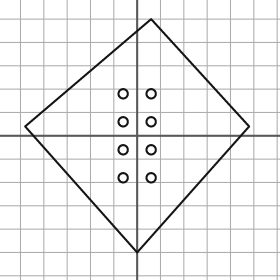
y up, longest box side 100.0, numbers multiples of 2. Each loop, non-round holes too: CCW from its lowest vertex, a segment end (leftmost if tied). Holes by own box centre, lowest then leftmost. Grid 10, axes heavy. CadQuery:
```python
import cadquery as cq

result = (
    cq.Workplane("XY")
    .moveTo(0.0, -50.0)
    .lineTo(48.0, 4.0)
    .lineTo(6.0, 50.0)
    .lineTo(-48.0, 4.0)
    .close()
    .moveTo(-6.0, -18.0)
    .circle(2.0)
    .moveTo(6.0, -18.0)
    .circle(2.0)
    .moveTo(-6.0, -6.0)
    .circle(2.0)
    .moveTo(6.0, -6.0)
    .circle(2.0)
    .moveTo(-6.0, 6.0)
    .circle(2.0)
    .moveTo(6.0, 6.0)
    .circle(2.0)
    .moveTo(-6.0, 18.0)
    .circle(2.0)
    .moveTo(6.0, 18.0)
    .circle(2.0)
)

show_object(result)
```